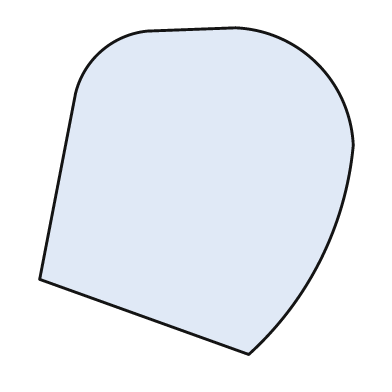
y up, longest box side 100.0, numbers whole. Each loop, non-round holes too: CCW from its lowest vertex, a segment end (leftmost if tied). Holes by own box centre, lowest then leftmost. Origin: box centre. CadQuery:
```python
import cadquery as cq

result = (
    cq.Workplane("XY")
    .moveTo(16.0, -50.0)
    .threePointArc((38.0, -21.0), (48.0, 14.0))
    .threePointArc((37.0, 39.0), (12.0, 50.0))
    .lineTo(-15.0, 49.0)
    .threePointArc((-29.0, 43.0), (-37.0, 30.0))
    .lineTo(-48.0, -27.0)
    .close()
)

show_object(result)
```